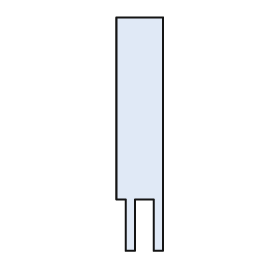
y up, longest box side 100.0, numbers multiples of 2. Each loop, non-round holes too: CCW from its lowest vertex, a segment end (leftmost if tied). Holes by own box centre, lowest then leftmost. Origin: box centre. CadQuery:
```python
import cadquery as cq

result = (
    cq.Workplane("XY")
    .moveTo(-6.0, -50.0)
    .lineTo(-2.0, -50.0)
    .lineTo(-2.0, -28.0)
    .lineTo(6.0, -28.0)
    .lineTo(6.0, -50.0)
    .lineTo(10.0, -50.0)
    .lineTo(10.0, 50.0)
    .lineTo(-10.0, 50.0)
    .lineTo(-10.0, -28.0)
    .lineTo(-6.0, -28.0)
    .close()
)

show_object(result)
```